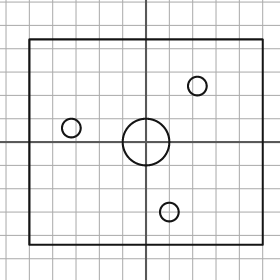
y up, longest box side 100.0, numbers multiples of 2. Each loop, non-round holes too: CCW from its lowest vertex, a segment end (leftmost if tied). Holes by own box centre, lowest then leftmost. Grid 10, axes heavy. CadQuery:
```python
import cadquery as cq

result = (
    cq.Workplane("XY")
    .moveTo(-50.0, -44.0)
    .lineTo(50.0, -44.0)
    .lineTo(50.0, 44.0)
    .lineTo(-50.0, 44.0)
    .close()
    .moveTo(10.0, -30.0)
    .circle(4.0)
    .moveTo(0.0, 0.0)
    .circle(10.0)
    .moveTo(-32.0, 6.0)
    .circle(4.0)
    .moveTo(22.0, 24.0)
    .circle(4.0)
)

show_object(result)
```